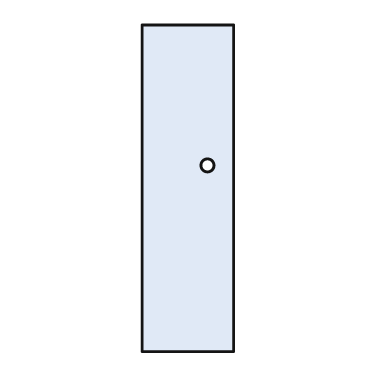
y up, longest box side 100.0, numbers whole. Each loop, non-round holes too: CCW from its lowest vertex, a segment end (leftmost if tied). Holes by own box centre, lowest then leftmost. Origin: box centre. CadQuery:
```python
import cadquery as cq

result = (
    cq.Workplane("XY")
    .moveTo(-14.0, -50.0)
    .lineTo(14.0, -50.0)
    .lineTo(14.0, 50.0)
    .lineTo(-14.0, 50.0)
    .close()
    .moveTo(6.0, 7.0)
    .circle(2.0)
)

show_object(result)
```